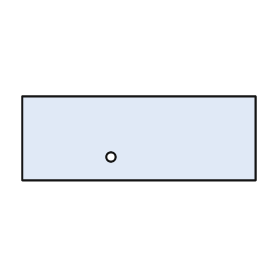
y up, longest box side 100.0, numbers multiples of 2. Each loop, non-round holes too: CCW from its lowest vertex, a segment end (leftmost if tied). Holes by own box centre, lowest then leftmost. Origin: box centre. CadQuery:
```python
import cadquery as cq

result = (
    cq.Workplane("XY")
    .moveTo(-50.0, -18.0)
    .lineTo(50.0, -18.0)
    .lineTo(50.0, 18.0)
    .lineTo(-50.0, 18.0)
    .close()
    .moveTo(-12.0, -8.0)
    .circle(2.0)
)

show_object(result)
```